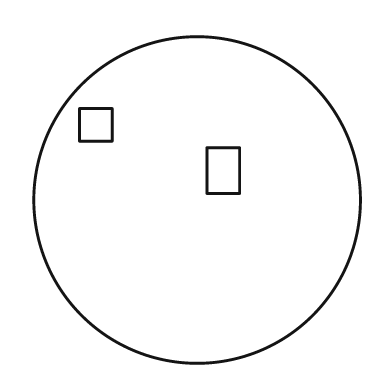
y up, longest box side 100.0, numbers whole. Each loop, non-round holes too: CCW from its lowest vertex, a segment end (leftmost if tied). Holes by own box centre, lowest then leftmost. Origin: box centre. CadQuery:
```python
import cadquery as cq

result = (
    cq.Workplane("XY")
    .moveTo(0.0, 0.0)
    .circle(50.0)
    .moveTo(3.0, 2.0)
    .lineTo(13.0, 2.0)
    .lineTo(13.0, 16.0)
    .lineTo(3.0, 16.0)
    .close()
    .moveTo(-36.0, 18.0)
    .lineTo(-26.0, 18.0)
    .lineTo(-26.0, 28.0)
    .lineTo(-36.0, 28.0)
    .close()
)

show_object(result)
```